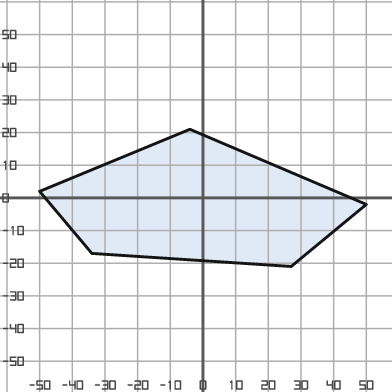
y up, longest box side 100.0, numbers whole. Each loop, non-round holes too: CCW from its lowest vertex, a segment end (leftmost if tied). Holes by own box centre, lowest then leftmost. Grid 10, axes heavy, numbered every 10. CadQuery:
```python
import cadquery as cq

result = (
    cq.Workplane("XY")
    .moveTo(27.0, -21.0)
    .lineTo(50.0, -2.0)
    .lineTo(-4.0, 21.0)
    .lineTo(-50.0, 2.0)
    .lineTo(-34.0, -17.0)
    .close()
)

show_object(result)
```